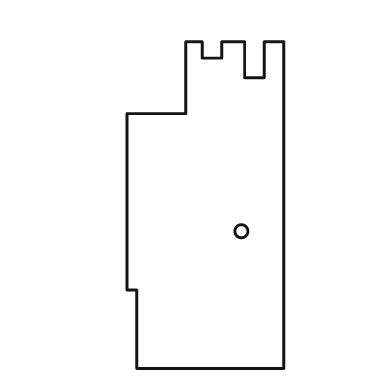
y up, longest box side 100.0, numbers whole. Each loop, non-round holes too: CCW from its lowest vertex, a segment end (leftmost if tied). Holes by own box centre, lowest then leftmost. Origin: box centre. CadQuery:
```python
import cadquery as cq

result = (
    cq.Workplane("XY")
    .moveTo(-21.0, -50.0)
    .lineTo(24.0, -50.0)
    .lineTo(24.0, 50.0)
    .lineTo(18.0, 50.0)
    .lineTo(18.0, 39.0)
    .lineTo(12.0, 39.0)
    .lineTo(12.0, 50.0)
    .lineTo(5.0, 50.0)
    .lineTo(5.0, 45.0)
    .lineTo(-1.0, 45.0)
    .lineTo(-1.0, 50.0)
    .lineTo(-6.0, 50.0)
    .lineTo(-6.0, 28.0)
    .lineTo(-24.0, 28.0)
    .lineTo(-24.0, -26.0)
    .lineTo(-21.0, -26.0)
    .close()
    .moveTo(11.0, -8.0)
    .circle(2.0)
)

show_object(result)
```